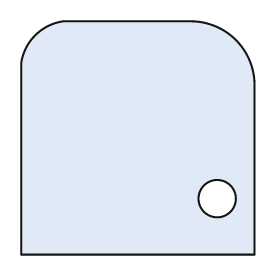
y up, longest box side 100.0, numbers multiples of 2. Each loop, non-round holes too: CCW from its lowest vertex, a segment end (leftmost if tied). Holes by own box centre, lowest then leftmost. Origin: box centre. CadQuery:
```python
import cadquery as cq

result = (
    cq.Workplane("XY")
    .moveTo(-50.0, -50.0)
    .lineTo(50.0, -50.0)
    .lineTo(50.0, 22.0)
    .threePointArc((42.0, 42.0), (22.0, 50.0))
    .lineTo(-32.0, 50.0)
    .threePointArc((-44.0, 44.0), (-50.0, 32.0))
    .close()
    .moveTo(34.0, -26.0)
    .circle(8.0)
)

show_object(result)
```